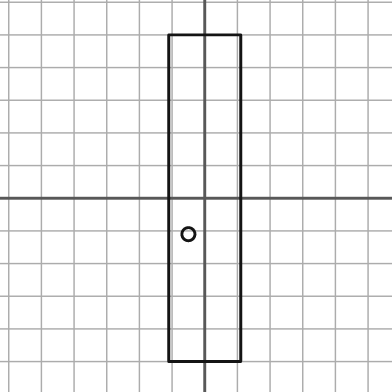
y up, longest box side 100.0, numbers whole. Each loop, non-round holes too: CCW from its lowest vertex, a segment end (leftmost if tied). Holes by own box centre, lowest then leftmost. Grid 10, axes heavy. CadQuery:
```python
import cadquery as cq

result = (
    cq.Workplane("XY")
    .moveTo(-11.0, -50.0)
    .lineTo(11.0, -50.0)
    .lineTo(11.0, 50.0)
    .lineTo(-11.0, 50.0)
    .close()
    .moveTo(-5.0, -11.0)
    .circle(2.0)
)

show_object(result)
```